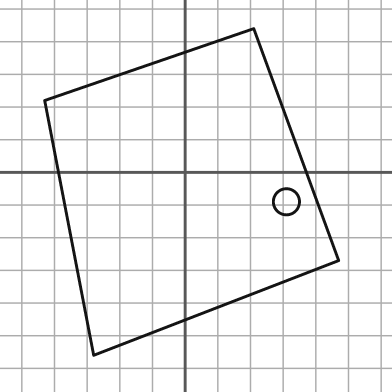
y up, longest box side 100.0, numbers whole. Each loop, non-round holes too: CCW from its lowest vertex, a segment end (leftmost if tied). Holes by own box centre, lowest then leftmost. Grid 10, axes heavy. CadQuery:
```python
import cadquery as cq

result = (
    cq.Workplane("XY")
    .moveTo(-28.0, -56.0)
    .lineTo(47.0, -27.0)
    .lineTo(21.0, 44.0)
    .lineTo(-43.0, 22.0)
    .close()
    .moveTo(31.0, -9.0)
    .circle(4.0)
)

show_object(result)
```